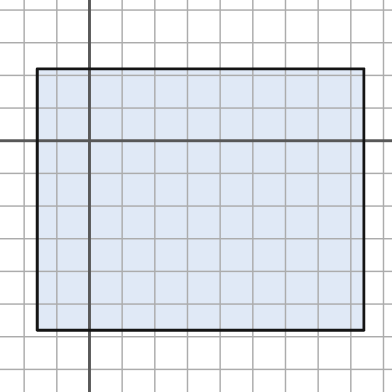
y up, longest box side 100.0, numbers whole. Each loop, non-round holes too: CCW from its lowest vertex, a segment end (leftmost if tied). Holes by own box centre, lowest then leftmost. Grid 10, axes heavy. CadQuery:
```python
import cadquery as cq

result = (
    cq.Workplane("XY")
    .moveTo(-16.0, -58.0)
    .lineTo(84.0, -58.0)
    .lineTo(84.0, 22.0)
    .lineTo(-16.0, 22.0)
    .close()
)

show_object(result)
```